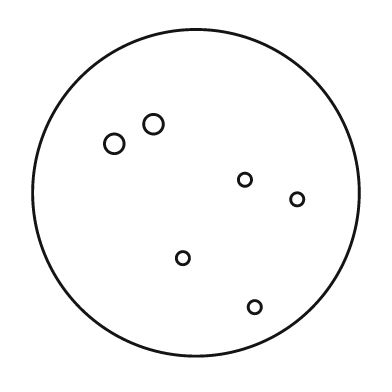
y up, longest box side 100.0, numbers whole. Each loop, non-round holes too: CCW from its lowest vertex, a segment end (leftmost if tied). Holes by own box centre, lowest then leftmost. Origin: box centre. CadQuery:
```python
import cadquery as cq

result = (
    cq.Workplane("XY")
    .moveTo(0.0, 0.0)
    .circle(50.0)
    .moveTo(18.0, -35.0)
    .circle(2.0)
    .moveTo(-4.0, -20.0)
    .circle(2.0)
    .moveTo(31.0, -2.0)
    .circle(2.0)
    .moveTo(15.0, 4.0)
    .circle(2.0)
    .moveTo(-25.0, 15.0)
    .circle(3.0)
    .moveTo(-13.0, 21.0)
    .circle(3.0)
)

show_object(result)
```